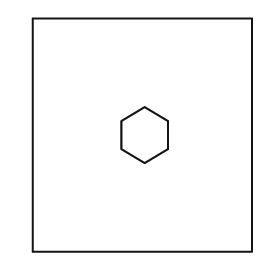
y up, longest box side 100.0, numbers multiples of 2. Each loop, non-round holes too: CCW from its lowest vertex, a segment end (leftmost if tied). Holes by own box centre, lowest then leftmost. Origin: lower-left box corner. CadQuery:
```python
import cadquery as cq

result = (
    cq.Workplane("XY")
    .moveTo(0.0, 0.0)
    .lineTo(94.0, 0.0)
    .lineTo(94.0, 100.0)
    .lineTo(0.0, 100.0)
    .close()
    .moveTo(48.0, 38.0)
    .lineTo(58.0, 44.0)
    .lineTo(58.0, 56.0)
    .lineTo(48.0, 62.0)
    .lineTo(38.0, 56.0)
    .lineTo(38.0, 44.0)
    .close()
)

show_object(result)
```